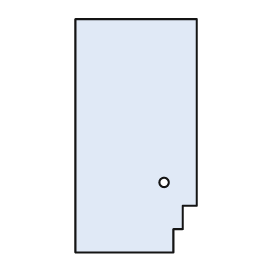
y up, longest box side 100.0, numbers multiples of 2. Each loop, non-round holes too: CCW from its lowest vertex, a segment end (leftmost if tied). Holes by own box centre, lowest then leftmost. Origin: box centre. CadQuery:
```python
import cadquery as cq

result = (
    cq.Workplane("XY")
    .moveTo(-26.0, -50.0)
    .lineTo(16.0, -50.0)
    .lineTo(16.0, -40.0)
    .lineTo(20.0, -40.0)
    .lineTo(20.0, -30.0)
    .lineTo(26.0, -30.0)
    .lineTo(26.0, 50.0)
    .lineTo(-26.0, 50.0)
    .close()
    .moveTo(12.0, -20.0)
    .circle(2.0)
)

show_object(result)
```